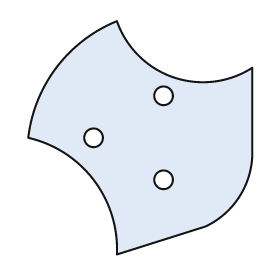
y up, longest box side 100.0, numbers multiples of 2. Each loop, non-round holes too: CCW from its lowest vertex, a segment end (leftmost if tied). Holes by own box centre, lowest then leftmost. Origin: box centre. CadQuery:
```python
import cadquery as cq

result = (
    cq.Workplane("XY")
    .moveTo(-10.0, -50.0)
    .lineTo(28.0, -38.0)
    .threePointArc((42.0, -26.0), (48.0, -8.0))
    .lineTo(48.0, 30.0)
    .threePointArc((14.0, 26.0), (-10.0, 50.0))
    .threePointArc((-36.0, 30.0), (-48.0, 0.0))
    .threePointArc((-20.0, -18.0), (-10.0, -50.0))
    .close()
    .moveTo(10.0, -18.0)
    .circle(4.0)
    .moveTo(-20.0, 0.0)
    .circle(4.0)
    .moveTo(10.0, 18.0)
    .circle(4.0)
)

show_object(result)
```